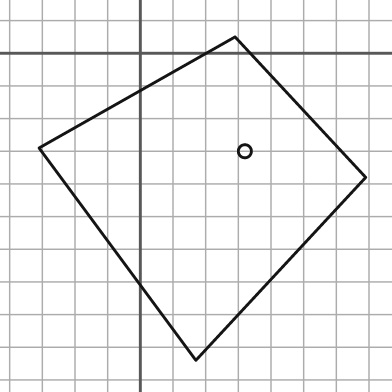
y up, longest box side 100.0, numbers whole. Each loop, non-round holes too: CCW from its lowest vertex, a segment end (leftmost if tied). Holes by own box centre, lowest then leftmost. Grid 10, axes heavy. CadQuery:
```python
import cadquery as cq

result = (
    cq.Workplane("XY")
    .moveTo(17.0, -94.0)
    .lineTo(69.0, -38.0)
    .lineTo(29.0, 5.0)
    .lineTo(-31.0, -29.0)
    .close()
    .moveTo(32.0, -30.0)
    .circle(2.0)
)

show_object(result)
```